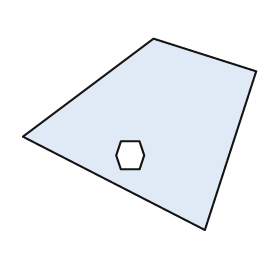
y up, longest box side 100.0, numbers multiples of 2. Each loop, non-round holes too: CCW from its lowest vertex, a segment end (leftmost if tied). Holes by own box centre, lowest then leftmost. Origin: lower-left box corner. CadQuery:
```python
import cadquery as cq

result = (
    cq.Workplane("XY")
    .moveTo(78.0, 0.0)
    .lineTo(100.0, 68.0)
    .lineTo(56.0, 82.0)
    .lineTo(0.0, 40.0)
    .close()
    .moveTo(42.0, 26.0)
    .lineTo(50.0, 26.0)
    .lineTo(52.0, 32.0)
    .lineTo(50.0, 38.0)
    .lineTo(42.0, 38.0)
    .lineTo(40.0, 32.0)
    .close()
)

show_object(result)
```